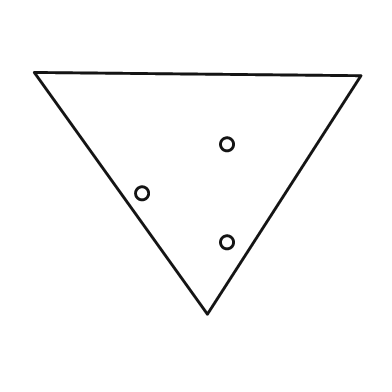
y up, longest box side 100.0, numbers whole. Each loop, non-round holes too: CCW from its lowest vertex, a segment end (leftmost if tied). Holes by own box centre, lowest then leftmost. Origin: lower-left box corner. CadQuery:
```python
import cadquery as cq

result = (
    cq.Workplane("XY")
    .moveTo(53.0, 0.0)
    .lineTo(100.0, 73.0)
    .lineTo(0.0, 74.0)
    .close()
    .moveTo(59.0, 22.0)
    .circle(2.0)
    .moveTo(33.0, 37.0)
    .circle(2.0)
    .moveTo(59.0, 52.0)
    .circle(2.0)
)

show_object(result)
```